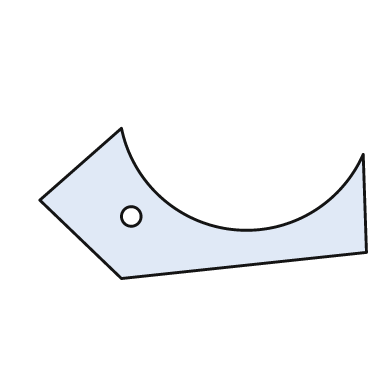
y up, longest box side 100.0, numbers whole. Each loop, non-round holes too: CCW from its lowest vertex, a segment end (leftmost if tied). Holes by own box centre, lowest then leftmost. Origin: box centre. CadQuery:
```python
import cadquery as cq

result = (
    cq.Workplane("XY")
    .moveTo(-25.0, -23.0)
    .lineTo(50.0, -15.0)
    .lineTo(49.0, 15.0)
    .threePointArc((9.0, -8.0), (-25.0, 23.0))
    .lineTo(-50.0, 1.0)
    .close()
    .moveTo(-22.0, -4.0)
    .circle(3.0)
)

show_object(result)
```